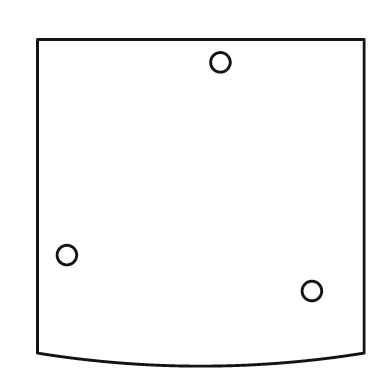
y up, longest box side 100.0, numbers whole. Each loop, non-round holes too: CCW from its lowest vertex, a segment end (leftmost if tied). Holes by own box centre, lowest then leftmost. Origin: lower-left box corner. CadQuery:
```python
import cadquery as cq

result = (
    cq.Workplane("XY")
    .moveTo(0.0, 4.0)
    .threePointArc((50.0, 0.0), (100.0, 4.0))
    .lineTo(100.0, 100.0)
    .lineTo(0.0, 100.0)
    .close()
    .moveTo(84.0, 23.0)
    .circle(3.0)
    .moveTo(9.0, 34.0)
    .circle(3.0)
    .moveTo(56.0, 93.0)
    .circle(3.0)
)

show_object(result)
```